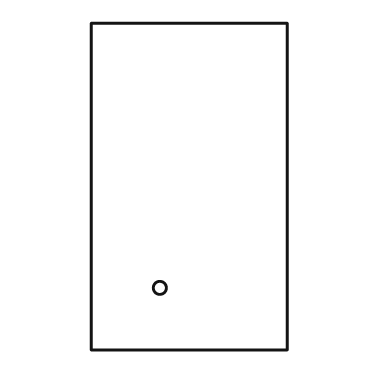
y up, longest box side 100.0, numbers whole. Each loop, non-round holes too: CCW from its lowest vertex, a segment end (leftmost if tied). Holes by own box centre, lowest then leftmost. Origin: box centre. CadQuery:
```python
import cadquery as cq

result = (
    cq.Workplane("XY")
    .moveTo(-30.0, -50.0)
    .lineTo(30.0, -50.0)
    .lineTo(30.0, 50.0)
    .lineTo(-30.0, 50.0)
    .close()
    .moveTo(-9.0, -31.0)
    .circle(2.0)
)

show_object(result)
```